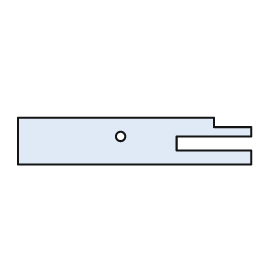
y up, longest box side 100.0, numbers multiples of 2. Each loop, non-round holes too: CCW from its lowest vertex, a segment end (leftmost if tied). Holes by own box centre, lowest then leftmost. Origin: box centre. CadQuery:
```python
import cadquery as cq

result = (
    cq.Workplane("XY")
    .moveTo(-50.0, -10.0)
    .lineTo(50.0, -10.0)
    .lineTo(50.0, -4.0)
    .lineTo(18.0, -4.0)
    .lineTo(18.0, 2.0)
    .lineTo(50.0, 2.0)
    .lineTo(50.0, 6.0)
    .lineTo(34.0, 6.0)
    .lineTo(34.0, 10.0)
    .lineTo(-50.0, 10.0)
    .close()
    .moveTo(-6.0, 2.0)
    .circle(2.0)
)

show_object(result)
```